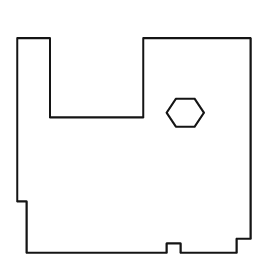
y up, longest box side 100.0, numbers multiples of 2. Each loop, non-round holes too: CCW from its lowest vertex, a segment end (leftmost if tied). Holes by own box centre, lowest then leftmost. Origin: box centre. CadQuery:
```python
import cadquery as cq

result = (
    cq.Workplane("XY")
    .moveTo(-46.0, -46.0)
    .lineTo(14.0, -46.0)
    .lineTo(14.0, -42.0)
    .lineTo(20.0, -42.0)
    .lineTo(20.0, -46.0)
    .lineTo(44.0, -46.0)
    .lineTo(44.0, -40.0)
    .lineTo(50.0, -40.0)
    .lineTo(50.0, 46.0)
    .lineTo(4.0, 46.0)
    .lineTo(4.0, 12.0)
    .lineTo(-36.0, 12.0)
    .lineTo(-36.0, 46.0)
    .lineTo(-50.0, 46.0)
    .lineTo(-50.0, -24.0)
    .lineTo(-46.0, -24.0)
    .close()
    .moveTo(18.0, 8.0)
    .lineTo(26.0, 8.0)
    .lineTo(30.0, 14.0)
    .lineTo(26.0, 20.0)
    .lineTo(18.0, 20.0)
    .lineTo(14.0, 14.0)
    .close()
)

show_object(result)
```